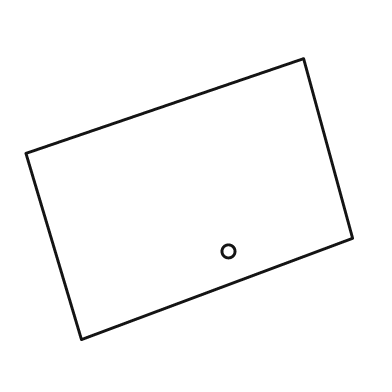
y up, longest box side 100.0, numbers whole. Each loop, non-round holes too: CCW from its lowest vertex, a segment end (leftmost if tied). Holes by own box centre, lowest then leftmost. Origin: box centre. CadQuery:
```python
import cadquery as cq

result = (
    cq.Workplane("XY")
    .moveTo(-33.0, -43.0)
    .lineTo(50.0, -12.0)
    .lineTo(35.0, 43.0)
    .lineTo(-50.0, 14.0)
    .close()
    .moveTo(12.0, -16.0)
    .circle(2.0)
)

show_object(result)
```